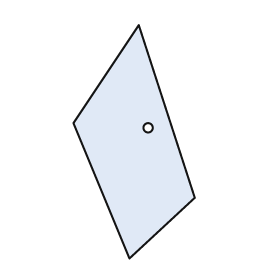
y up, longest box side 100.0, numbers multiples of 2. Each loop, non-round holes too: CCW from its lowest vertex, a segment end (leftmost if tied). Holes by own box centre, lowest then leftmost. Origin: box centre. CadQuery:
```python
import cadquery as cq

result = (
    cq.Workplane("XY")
    .moveTo(-2.0, -50.0)
    .lineTo(26.0, -24.0)
    .lineTo(2.0, 50.0)
    .lineTo(-26.0, 8.0)
    .close()
    .moveTo(6.0, 6.0)
    .circle(2.0)
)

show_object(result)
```